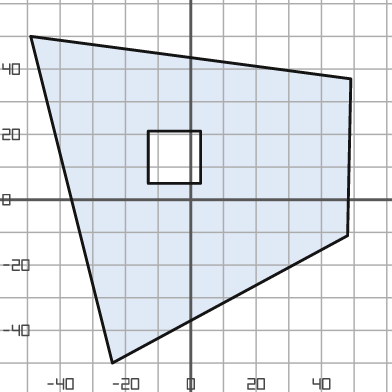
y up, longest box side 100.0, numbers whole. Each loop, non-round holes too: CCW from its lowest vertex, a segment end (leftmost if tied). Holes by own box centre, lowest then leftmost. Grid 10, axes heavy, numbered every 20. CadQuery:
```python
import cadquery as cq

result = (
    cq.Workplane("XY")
    .moveTo(-24.0, -50.0)
    .lineTo(48.0, -11.0)
    .lineTo(49.0, 37.0)
    .lineTo(-49.0, 50.0)
    .close()
    .moveTo(-13.0, 5.0)
    .lineTo(3.0, 5.0)
    .lineTo(3.0, 21.0)
    .lineTo(-13.0, 21.0)
    .close()
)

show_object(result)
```